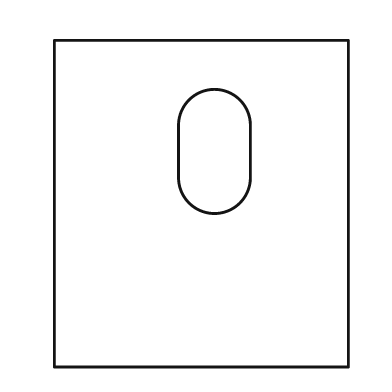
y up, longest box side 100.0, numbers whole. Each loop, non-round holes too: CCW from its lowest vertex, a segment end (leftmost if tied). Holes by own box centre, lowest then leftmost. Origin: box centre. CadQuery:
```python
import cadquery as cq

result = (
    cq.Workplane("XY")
    .moveTo(-45.0, -50.0)
    .lineTo(45.0, -50.0)
    .lineTo(45.0, 50.0)
    .lineTo(-45.0, 50.0)
    .close()
    .moveTo(-7.0, 8.0)
    .threePointArc((4.0, -3.0), (15.0, 8.0))
    .lineTo(15.0, 24.0)
    .threePointArc((4.0, 35.0), (-7.0, 24.0))
    .close()
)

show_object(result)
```